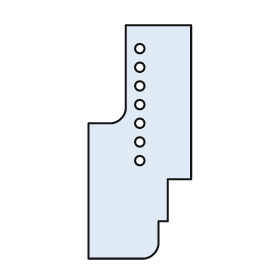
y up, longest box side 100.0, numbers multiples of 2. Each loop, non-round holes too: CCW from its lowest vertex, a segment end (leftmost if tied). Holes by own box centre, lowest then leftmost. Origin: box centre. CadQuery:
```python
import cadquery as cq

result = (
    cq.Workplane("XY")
    .moveTo(-22.0, -50.0)
    .lineTo(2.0, -50.0)
    .threePointArc((6.0, -48.0), (8.0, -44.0))
    .lineTo(8.0, -34.0)
    .lineTo(12.0, -34.0)
    .lineTo(12.0, -16.0)
    .lineTo(22.0, -16.0)
    .lineTo(22.0, 50.0)
    .lineTo(-6.0, 50.0)
    .lineTo(-6.0, 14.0)
    .threePointArc((-8.0, 10.0), (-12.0, 8.0))
    .lineTo(-22.0, 8.0)
    .close()
    .moveTo(0.0, -8.0)
    .circle(2.0)
    .moveTo(0.0, 0.0)
    .circle(2.0)
    .moveTo(0.0, 8.0)
    .circle(2.0)
    .moveTo(0.0, 16.0)
    .circle(2.0)
    .moveTo(0.0, 24.0)
    .circle(2.0)
    .moveTo(0.0, 32.0)
    .circle(2.0)
    .moveTo(0.0, 40.0)
    .circle(2.0)
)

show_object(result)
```